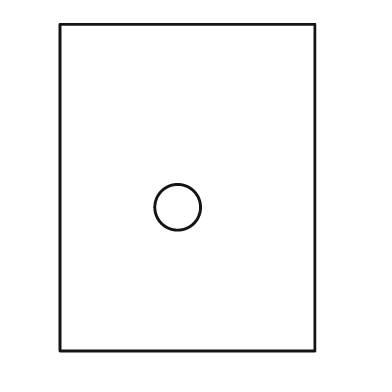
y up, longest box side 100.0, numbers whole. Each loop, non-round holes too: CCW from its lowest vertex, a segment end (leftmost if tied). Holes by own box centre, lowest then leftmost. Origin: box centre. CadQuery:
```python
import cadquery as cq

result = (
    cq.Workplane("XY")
    .moveTo(-39.0, -50.0)
    .lineTo(39.0, -50.0)
    .lineTo(39.0, 50.0)
    .lineTo(-39.0, 50.0)
    .close()
    .moveTo(-3.0, -6.0)
    .circle(7.0)
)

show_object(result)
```